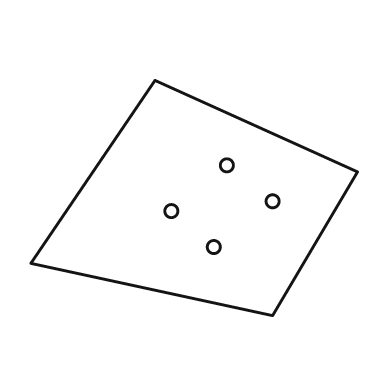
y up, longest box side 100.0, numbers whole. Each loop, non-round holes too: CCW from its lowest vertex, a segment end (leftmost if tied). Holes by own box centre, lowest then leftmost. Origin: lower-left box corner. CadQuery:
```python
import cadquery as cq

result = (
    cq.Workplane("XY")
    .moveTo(74.0, 0.0)
    .lineTo(100.0, 44.0)
    .lineTo(38.0, 72.0)
    .lineTo(0.0, 16.0)
    .close()
    .moveTo(56.0, 21.0)
    .circle(2.0)
    .moveTo(43.0, 32.0)
    .circle(2.0)
    .moveTo(74.0, 35.0)
    .circle(2.0)
    .moveTo(60.0, 46.0)
    .circle(2.0)
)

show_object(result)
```